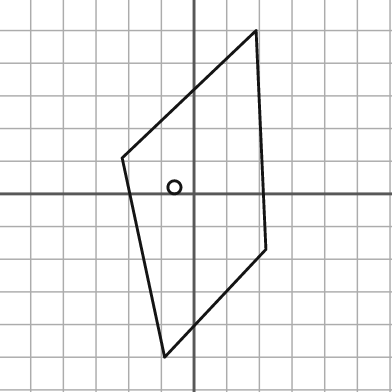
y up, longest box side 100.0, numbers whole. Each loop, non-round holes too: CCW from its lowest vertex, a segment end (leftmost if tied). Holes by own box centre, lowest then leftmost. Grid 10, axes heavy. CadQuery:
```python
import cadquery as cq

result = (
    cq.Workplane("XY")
    .moveTo(-9.0, -50.0)
    .lineTo(22.0, -17.0)
    .lineTo(19.0, 50.0)
    .lineTo(-22.0, 11.0)
    .close()
    .moveTo(-6.0, 2.0)
    .circle(2.0)
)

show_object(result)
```